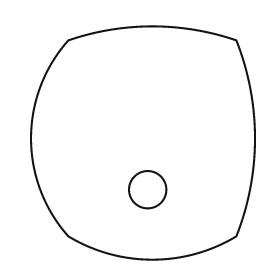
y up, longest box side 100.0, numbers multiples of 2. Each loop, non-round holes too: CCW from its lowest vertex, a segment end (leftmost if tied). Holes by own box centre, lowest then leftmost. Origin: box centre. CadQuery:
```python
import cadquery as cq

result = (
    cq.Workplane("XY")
    .moveTo(-32.0, -40.0)
    .threePointArc((4.0, -50.0), (40.0, -40.0))
    .threePointArc((48.0, 2.0), (40.0, 44.0))
    .threePointArc((4.0, 50.0), (-32.0, 44.0))
    .threePointArc((-48.0, 2.0), (-32.0, -40.0))
    .close()
    .moveTo(2.0, -20.0)
    .circle(8.0)
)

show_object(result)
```